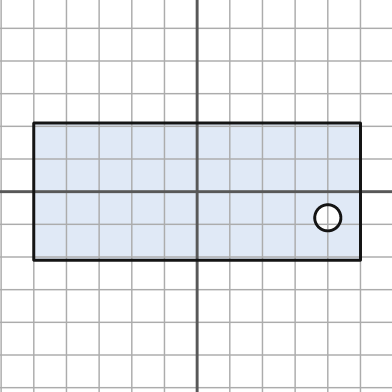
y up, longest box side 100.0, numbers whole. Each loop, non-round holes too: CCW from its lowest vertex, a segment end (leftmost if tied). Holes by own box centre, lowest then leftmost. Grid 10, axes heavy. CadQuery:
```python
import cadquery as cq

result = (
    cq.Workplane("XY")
    .moveTo(-50.0, -21.0)
    .lineTo(50.0, -21.0)
    .lineTo(50.0, 21.0)
    .lineTo(-50.0, 21.0)
    .close()
    .moveTo(40.0, -8.0)
    .circle(4.0)
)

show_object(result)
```